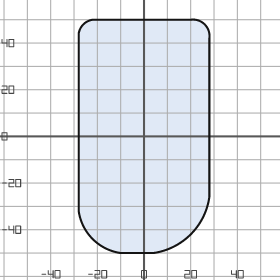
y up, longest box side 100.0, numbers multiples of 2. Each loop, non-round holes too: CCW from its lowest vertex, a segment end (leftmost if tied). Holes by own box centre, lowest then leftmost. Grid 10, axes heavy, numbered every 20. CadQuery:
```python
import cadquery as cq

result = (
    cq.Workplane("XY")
    .moveTo(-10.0, -50.0)
    .lineTo(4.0, -50.0)
    .threePointArc((20.0, -42.0), (28.0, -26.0))
    .lineTo(28.0, 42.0)
    .threePointArc((26.0, 48.0), (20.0, 50.0))
    .lineTo(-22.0, 50.0)
    .threePointArc((-26.0, 48.0), (-28.0, 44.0))
    .lineTo(-28.0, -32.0)
    .threePointArc((-22.0, -44.0), (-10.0, -50.0))
    .close()
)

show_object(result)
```